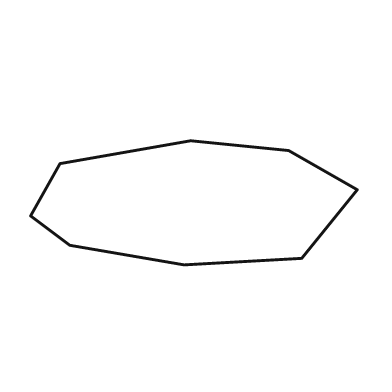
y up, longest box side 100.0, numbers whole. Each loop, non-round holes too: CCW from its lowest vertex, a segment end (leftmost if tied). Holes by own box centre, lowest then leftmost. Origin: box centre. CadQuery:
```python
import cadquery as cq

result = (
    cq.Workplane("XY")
    .moveTo(-3.0, -19.0)
    .lineTo(33.0, -17.0)
    .lineTo(50.0, 4.0)
    .lineTo(29.0, 16.0)
    .lineTo(-1.0, 19.0)
    .lineTo(-41.0, 12.0)
    .lineTo(-50.0, -4.0)
    .lineTo(-38.0, -13.0)
    .close()
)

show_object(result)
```